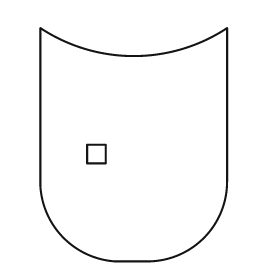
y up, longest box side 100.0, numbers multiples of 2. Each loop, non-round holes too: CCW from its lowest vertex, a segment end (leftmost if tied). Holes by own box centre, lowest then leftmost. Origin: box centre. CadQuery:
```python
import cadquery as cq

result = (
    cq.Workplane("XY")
    .moveTo(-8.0, -50.0)
    .lineTo(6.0, -50.0)
    .threePointArc((30.0, -40.0), (40.0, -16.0))
    .lineTo(40.0, 50.0)
    .threePointArc((0.0, 38.0), (-40.0, 50.0))
    .lineTo(-40.0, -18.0)
    .threePointArc((-30.0, -40.0), (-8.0, -50.0))
    .close()
    .moveTo(-20.0, -8.0)
    .lineTo(-12.0, -8.0)
    .lineTo(-12.0, 0.0)
    .lineTo(-20.0, 0.0)
    .close()
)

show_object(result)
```